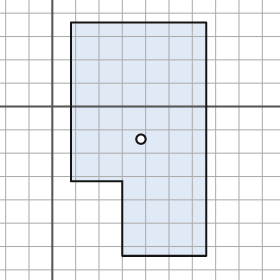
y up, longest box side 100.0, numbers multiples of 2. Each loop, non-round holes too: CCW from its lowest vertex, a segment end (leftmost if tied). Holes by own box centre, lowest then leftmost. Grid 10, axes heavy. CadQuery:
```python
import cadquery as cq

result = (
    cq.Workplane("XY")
    .moveTo(30.0, -64.0)
    .lineTo(66.0, -64.0)
    .lineTo(66.0, 36.0)
    .lineTo(8.0, 36.0)
    .lineTo(8.0, -32.0)
    .lineTo(30.0, -32.0)
    .close()
    .moveTo(38.0, -14.0)
    .circle(2.0)
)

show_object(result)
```